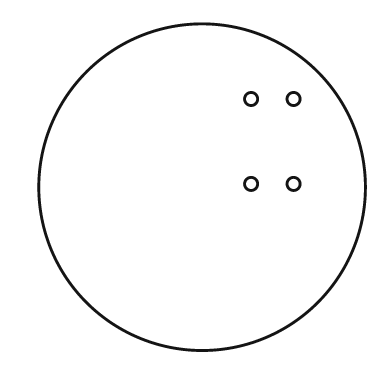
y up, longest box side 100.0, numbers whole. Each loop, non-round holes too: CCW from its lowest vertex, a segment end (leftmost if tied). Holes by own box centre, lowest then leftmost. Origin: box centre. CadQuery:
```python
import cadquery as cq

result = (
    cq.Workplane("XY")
    .moveTo(0.0, 0.0)
    .circle(50.0)
    .moveTo(15.0, 1.0)
    .circle(2.0)
    .moveTo(28.0, 1.0)
    .circle(2.0)
    .moveTo(15.0, 27.0)
    .circle(2.0)
    .moveTo(28.0, 27.0)
    .circle(2.0)
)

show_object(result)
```